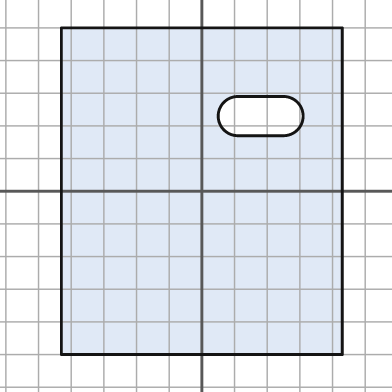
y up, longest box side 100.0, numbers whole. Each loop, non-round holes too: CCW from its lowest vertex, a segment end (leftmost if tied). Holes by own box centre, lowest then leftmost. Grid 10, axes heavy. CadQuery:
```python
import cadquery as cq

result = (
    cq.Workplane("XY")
    .moveTo(-43.0, -50.0)
    .lineTo(43.0, -50.0)
    .lineTo(43.0, 50.0)
    .lineTo(-43.0, 50.0)
    .close()
    .moveTo(11.0, 17.0)
    .lineTo(25.0, 17.0)
    .threePointArc((31.0, 23.0), (25.0, 29.0))
    .lineTo(11.0, 29.0)
    .threePointArc((5.0, 23.0), (11.0, 17.0))
    .close()
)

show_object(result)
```